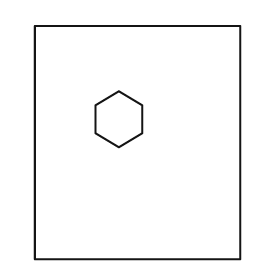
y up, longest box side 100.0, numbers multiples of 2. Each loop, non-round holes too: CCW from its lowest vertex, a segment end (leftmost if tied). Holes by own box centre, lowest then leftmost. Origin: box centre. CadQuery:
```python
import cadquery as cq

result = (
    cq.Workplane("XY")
    .moveTo(-44.0, -50.0)
    .lineTo(44.0, -50.0)
    .lineTo(44.0, 50.0)
    .lineTo(-44.0, 50.0)
    .close()
    .moveTo(-8.0, -2.0)
    .lineTo(2.0, 4.0)
    .lineTo(2.0, 16.0)
    .lineTo(-8.0, 22.0)
    .lineTo(-18.0, 16.0)
    .lineTo(-18.0, 4.0)
    .close()
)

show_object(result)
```